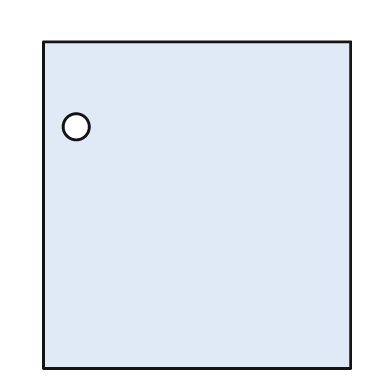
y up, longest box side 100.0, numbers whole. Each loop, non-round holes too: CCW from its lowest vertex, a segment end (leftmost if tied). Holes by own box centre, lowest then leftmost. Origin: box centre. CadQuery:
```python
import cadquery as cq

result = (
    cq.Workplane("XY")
    .moveTo(-47.0, -50.0)
    .lineTo(47.0, -50.0)
    .lineTo(47.0, 50.0)
    .lineTo(-47.0, 50.0)
    .close()
    .moveTo(-37.0, 24.0)
    .circle(4.0)
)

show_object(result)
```